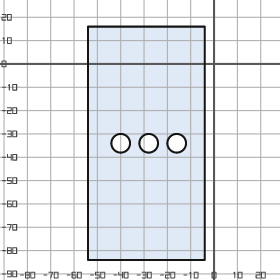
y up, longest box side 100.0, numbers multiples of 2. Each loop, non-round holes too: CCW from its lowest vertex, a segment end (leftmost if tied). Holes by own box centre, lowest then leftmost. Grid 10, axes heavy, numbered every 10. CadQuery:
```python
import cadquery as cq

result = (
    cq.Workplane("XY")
    .moveTo(-54.0, -84.0)
    .lineTo(-4.0, -84.0)
    .lineTo(-4.0, 16.0)
    .lineTo(-54.0, 16.0)
    .close()
    .moveTo(-40.0, -34.0)
    .circle(4.0)
    .moveTo(-28.0, -34.0)
    .circle(4.0)
    .moveTo(-16.0, -34.0)
    .circle(4.0)
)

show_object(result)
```